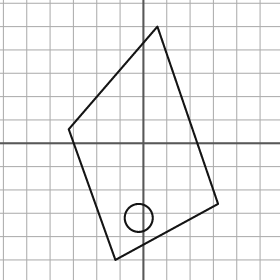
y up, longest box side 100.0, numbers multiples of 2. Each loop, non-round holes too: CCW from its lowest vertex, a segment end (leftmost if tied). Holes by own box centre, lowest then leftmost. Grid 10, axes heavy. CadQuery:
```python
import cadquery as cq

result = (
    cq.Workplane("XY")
    .moveTo(-12.0, -50.0)
    .lineTo(32.0, -26.0)
    .lineTo(6.0, 50.0)
    .lineTo(-32.0, 6.0)
    .close()
    .moveTo(-2.0, -32.0)
    .circle(6.0)
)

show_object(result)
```